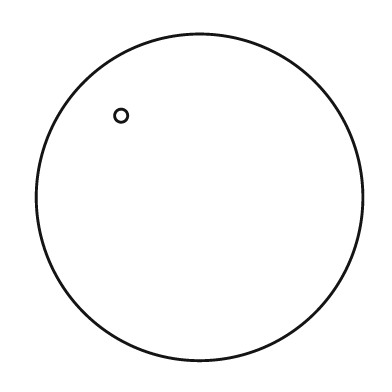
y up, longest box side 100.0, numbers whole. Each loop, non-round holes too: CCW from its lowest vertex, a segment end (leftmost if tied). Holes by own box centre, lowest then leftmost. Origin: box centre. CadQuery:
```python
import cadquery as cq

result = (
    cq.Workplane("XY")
    .moveTo(0.0, 0.0)
    .circle(50.0)
    .moveTo(-24.0, 25.0)
    .circle(2.0)
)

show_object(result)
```